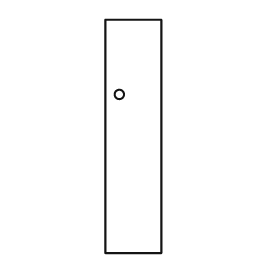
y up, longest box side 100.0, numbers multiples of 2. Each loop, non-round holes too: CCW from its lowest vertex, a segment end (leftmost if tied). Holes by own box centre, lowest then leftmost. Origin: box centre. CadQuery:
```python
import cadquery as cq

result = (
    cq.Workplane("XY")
    .moveTo(-12.0, -50.0)
    .lineTo(12.0, -50.0)
    .lineTo(12.0, 50.0)
    .lineTo(-12.0, 50.0)
    .close()
    .moveTo(-6.0, 18.0)
    .circle(2.0)
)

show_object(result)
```